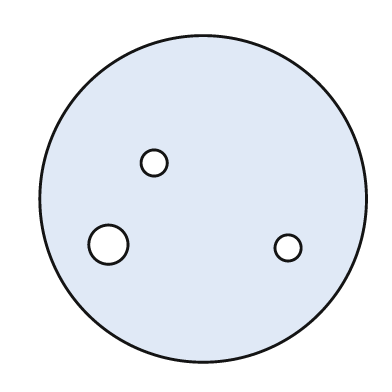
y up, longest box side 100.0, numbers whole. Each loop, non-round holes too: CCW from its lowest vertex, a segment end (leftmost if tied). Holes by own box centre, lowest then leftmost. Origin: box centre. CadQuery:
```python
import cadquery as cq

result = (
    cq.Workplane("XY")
    .moveTo(0.0, 0.0)
    .circle(50.0)
    .moveTo(26.0, -15.0)
    .circle(4.0)
    .moveTo(-29.0, -14.0)
    .circle(6.0)
    .moveTo(-15.0, 11.0)
    .circle(4.0)
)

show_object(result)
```